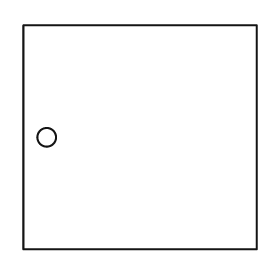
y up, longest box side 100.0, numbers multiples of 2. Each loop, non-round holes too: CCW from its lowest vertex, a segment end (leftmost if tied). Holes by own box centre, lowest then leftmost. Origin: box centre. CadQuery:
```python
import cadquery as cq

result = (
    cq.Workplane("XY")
    .moveTo(-50.0, -48.0)
    .lineTo(50.0, -48.0)
    .lineTo(50.0, 48.0)
    .lineTo(-50.0, 48.0)
    .close()
    .moveTo(-40.0, 0.0)
    .circle(4.0)
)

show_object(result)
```